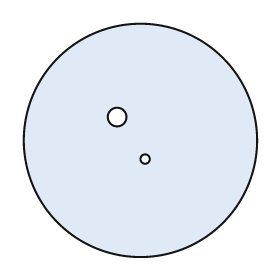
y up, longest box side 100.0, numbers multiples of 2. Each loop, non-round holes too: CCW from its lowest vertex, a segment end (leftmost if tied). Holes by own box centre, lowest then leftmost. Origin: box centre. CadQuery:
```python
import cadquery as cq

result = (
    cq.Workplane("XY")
    .moveTo(0.0, 0.0)
    .circle(50.0)
    .moveTo(2.0, -8.0)
    .circle(2.0)
    .moveTo(-10.0, 10.0)
    .circle(4.0)
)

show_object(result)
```